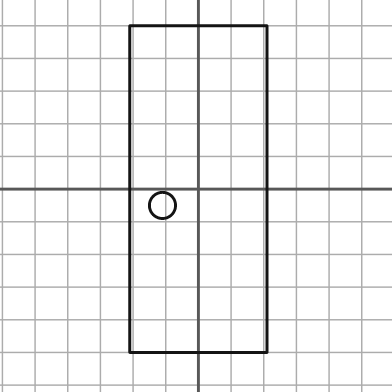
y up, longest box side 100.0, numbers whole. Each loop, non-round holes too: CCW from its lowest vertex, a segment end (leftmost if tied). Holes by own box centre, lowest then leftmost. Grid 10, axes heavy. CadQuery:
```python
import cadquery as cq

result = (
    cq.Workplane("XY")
    .moveTo(-21.0, -50.0)
    .lineTo(21.0, -50.0)
    .lineTo(21.0, 50.0)
    .lineTo(-21.0, 50.0)
    .close()
    .moveTo(-11.0, -5.0)
    .circle(4.0)
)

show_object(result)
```